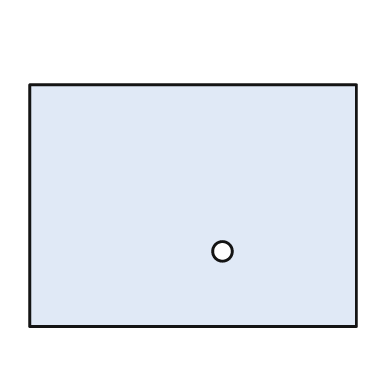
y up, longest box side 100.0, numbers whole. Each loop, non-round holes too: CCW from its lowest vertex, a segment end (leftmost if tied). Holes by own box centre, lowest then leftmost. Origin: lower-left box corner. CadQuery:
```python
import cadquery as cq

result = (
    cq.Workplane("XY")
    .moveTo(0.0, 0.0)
    .lineTo(100.0, 0.0)
    .lineTo(100.0, 74.0)
    .lineTo(0.0, 74.0)
    .close()
    .moveTo(59.0, 23.0)
    .circle(3.0)
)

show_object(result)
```